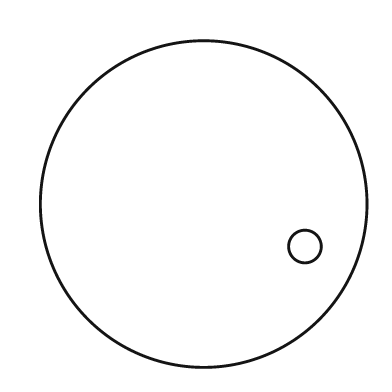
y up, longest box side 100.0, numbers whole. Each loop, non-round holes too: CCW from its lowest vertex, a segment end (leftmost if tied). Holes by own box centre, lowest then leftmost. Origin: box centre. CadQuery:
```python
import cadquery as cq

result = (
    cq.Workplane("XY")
    .moveTo(0.0, 0.0)
    .circle(50.0)
    .moveTo(31.0, -13.0)
    .circle(5.0)
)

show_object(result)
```